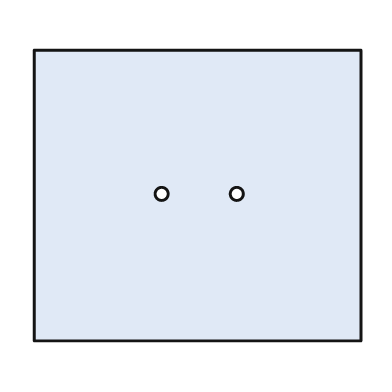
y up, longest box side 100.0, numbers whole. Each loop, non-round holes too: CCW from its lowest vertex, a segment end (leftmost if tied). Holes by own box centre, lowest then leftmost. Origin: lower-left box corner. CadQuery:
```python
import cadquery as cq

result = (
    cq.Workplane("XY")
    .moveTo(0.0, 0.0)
    .lineTo(100.0, 0.0)
    .lineTo(100.0, 89.0)
    .lineTo(0.0, 89.0)
    .close()
    .moveTo(39.0, 45.0)
    .circle(2.0)
    .moveTo(62.0, 45.0)
    .circle(2.0)
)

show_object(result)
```